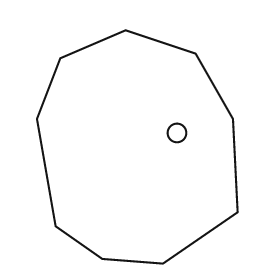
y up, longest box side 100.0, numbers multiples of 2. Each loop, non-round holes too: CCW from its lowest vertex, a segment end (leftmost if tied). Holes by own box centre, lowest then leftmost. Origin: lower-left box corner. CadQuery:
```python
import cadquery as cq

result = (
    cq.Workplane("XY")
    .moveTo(54.0, 0.0)
    .lineTo(86.0, 22.0)
    .lineTo(84.0, 62.0)
    .lineTo(68.0, 90.0)
    .lineTo(38.0, 100.0)
    .lineTo(10.0, 88.0)
    .lineTo(0.0, 62.0)
    .lineTo(8.0, 16.0)
    .lineTo(28.0, 2.0)
    .close()
    .moveTo(60.0, 56.0)
    .circle(4.0)
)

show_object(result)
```